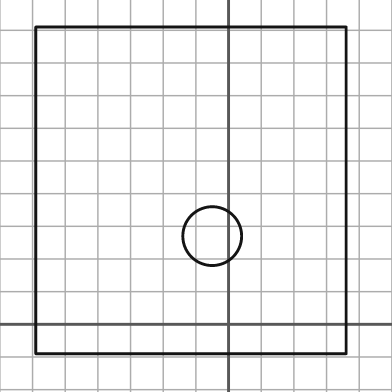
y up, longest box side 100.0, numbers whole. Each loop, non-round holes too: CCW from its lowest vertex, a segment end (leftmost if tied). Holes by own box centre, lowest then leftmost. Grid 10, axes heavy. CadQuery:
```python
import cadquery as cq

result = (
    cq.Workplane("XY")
    .moveTo(-59.0, -9.0)
    .lineTo(36.0, -9.0)
    .lineTo(36.0, 91.0)
    .lineTo(-59.0, 91.0)
    .close()
    .moveTo(-5.0, 27.0)
    .circle(9.0)
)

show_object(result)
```